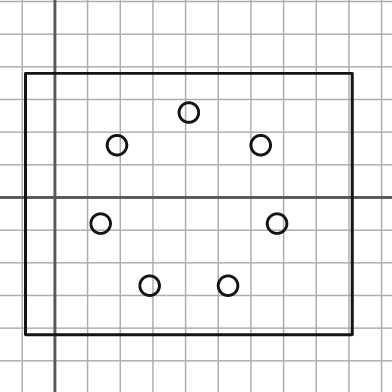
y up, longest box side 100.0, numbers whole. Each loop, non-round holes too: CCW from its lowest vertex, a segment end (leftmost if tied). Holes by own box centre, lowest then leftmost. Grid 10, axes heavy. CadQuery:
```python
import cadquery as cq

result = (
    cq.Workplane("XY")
    .moveTo(-9.0, -42.0)
    .lineTo(91.0, -42.0)
    .lineTo(91.0, 38.0)
    .lineTo(-9.0, 38.0)
    .close()
    .moveTo(29.0, -27.0)
    .circle(3.0)
    .moveTo(53.0, -27.0)
    .circle(3.0)
    .moveTo(14.0, -8.0)
    .circle(3.0)
    .moveTo(68.0, -8.0)
    .circle(3.0)
    .moveTo(19.0, 16.0)
    .circle(3.0)
    .moveTo(63.0, 16.0)
    .circle(3.0)
    .moveTo(41.0, 26.0)
    .circle(3.0)
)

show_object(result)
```